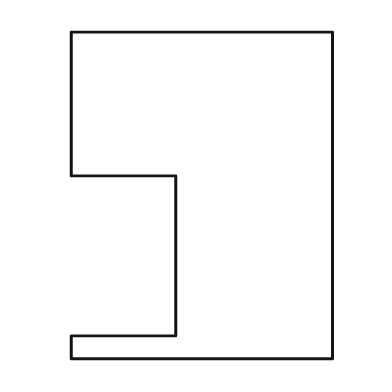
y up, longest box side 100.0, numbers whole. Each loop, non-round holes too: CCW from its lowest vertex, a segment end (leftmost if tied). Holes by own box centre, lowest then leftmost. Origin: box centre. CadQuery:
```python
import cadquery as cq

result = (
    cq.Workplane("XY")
    .moveTo(-40.0, -50.0)
    .lineTo(40.0, -50.0)
    .lineTo(40.0, 50.0)
    .lineTo(-40.0, 50.0)
    .lineTo(-40.0, 6.0)
    .lineTo(-8.0, 6.0)
    .lineTo(-8.0, -43.0)
    .lineTo(-40.0, -43.0)
    .close()
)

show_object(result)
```